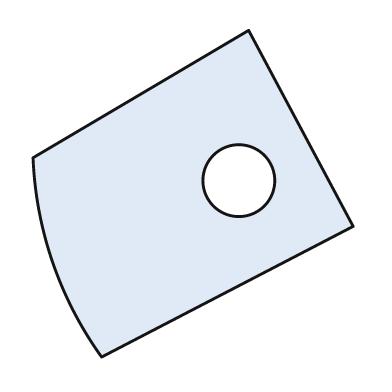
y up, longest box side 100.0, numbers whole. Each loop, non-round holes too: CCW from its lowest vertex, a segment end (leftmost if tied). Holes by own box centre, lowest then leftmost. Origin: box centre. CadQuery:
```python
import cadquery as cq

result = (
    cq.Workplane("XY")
    .moveTo(-28.0, -50.0)
    .lineTo(49.0, -10.0)
    .lineTo(17.0, 50.0)
    .lineTo(-49.0, 11.0)
    .threePointArc((-43.0, -21.0), (-28.0, -50.0))
    .close()
    .moveTo(14.0, 4.0)
    .circle(11.0)
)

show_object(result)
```